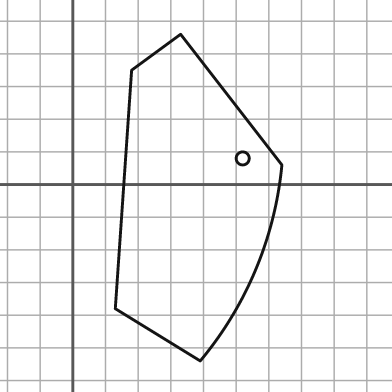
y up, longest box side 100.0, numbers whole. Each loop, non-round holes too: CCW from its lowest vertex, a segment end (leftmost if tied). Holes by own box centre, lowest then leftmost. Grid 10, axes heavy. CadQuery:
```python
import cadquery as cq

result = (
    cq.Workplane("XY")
    .moveTo(39.0, -54.0)
    .threePointArc((56.0, -26.0), (64.0, 6.0))
    .lineTo(33.0, 46.0)
    .lineTo(18.0, 35.0)
    .lineTo(13.0, -38.0)
    .close()
    .moveTo(52.0, 8.0)
    .circle(2.0)
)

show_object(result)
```